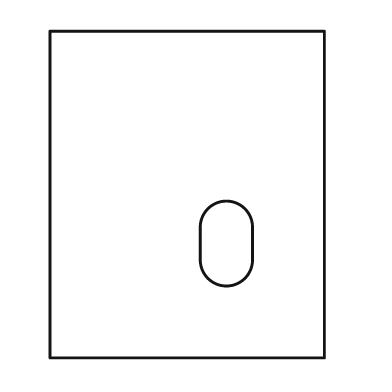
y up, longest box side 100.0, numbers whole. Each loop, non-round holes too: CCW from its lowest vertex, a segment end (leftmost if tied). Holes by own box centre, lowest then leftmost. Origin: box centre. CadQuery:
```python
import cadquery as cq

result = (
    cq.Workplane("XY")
    .moveTo(-42.0, -50.0)
    .lineTo(42.0, -50.0)
    .lineTo(42.0, 50.0)
    .lineTo(-42.0, 50.0)
    .close()
    .moveTo(4.0, -20.0)
    .threePointArc((12.0, -28.0), (20.0, -20.0))
    .lineTo(20.0, -10.0)
    .threePointArc((12.0, -2.0), (4.0, -10.0))
    .close()
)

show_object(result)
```